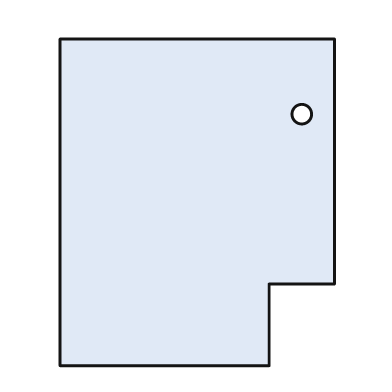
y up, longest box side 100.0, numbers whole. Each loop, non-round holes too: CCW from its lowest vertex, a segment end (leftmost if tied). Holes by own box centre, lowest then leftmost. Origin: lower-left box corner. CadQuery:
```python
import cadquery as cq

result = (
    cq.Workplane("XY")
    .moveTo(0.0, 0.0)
    .lineTo(64.0, 0.0)
    .lineTo(64.0, 25.0)
    .lineTo(84.0, 25.0)
    .lineTo(84.0, 100.0)
    .lineTo(0.0, 100.0)
    .close()
    .moveTo(74.0, 77.0)
    .circle(3.0)
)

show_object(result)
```